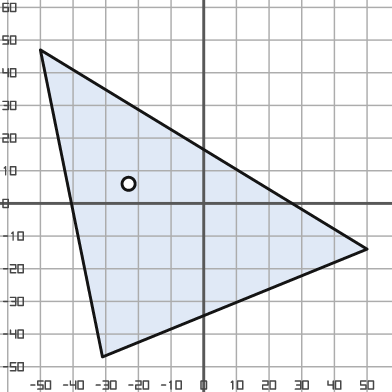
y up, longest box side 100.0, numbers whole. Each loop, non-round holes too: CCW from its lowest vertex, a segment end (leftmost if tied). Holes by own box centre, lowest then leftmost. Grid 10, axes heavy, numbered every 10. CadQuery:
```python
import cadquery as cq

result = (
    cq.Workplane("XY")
    .moveTo(-31.0, -47.0)
    .lineTo(50.0, -14.0)
    .lineTo(-50.0, 47.0)
    .close()
    .moveTo(-23.0, 6.0)
    .circle(2.0)
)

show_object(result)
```